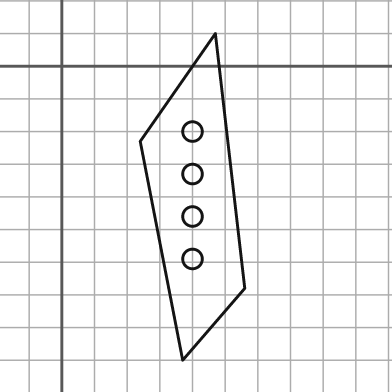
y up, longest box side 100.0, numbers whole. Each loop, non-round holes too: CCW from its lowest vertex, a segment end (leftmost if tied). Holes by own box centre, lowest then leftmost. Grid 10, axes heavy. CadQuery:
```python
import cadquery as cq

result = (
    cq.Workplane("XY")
    .moveTo(37.0, -90.0)
    .lineTo(56.0, -68.0)
    .lineTo(47.0, 10.0)
    .lineTo(24.0, -23.0)
    .close()
    .moveTo(40.0, -59.0)
    .circle(3.0)
    .moveTo(40.0, -46.0)
    .circle(3.0)
    .moveTo(40.0, -33.0)
    .circle(3.0)
    .moveTo(40.0, -20.0)
    .circle(3.0)
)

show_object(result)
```